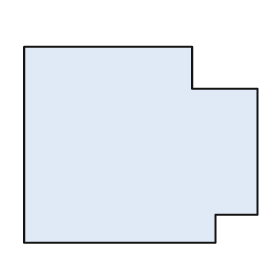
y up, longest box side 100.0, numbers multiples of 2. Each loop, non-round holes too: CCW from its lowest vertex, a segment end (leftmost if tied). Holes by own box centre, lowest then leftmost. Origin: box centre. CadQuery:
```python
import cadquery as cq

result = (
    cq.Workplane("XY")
    .moveTo(-50.0, -42.0)
    .lineTo(32.0, -42.0)
    .lineTo(32.0, -30.0)
    .lineTo(50.0, -30.0)
    .lineTo(50.0, 24.0)
    .lineTo(22.0, 24.0)
    .lineTo(22.0, 42.0)
    .lineTo(-50.0, 42.0)
    .close()
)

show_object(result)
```